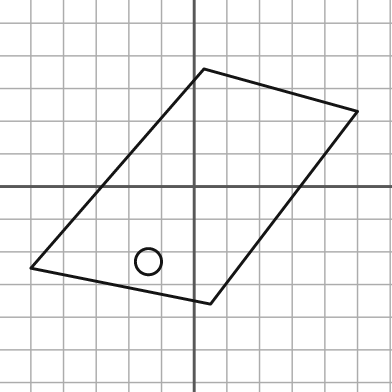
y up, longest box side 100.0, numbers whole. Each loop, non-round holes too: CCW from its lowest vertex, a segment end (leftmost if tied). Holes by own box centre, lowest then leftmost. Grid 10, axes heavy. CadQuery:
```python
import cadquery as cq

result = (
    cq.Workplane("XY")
    .moveTo(5.0, -36.0)
    .lineTo(50.0, 23.0)
    .lineTo(3.0, 36.0)
    .lineTo(-50.0, -25.0)
    .close()
    .moveTo(-14.0, -23.0)
    .circle(4.0)
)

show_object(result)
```